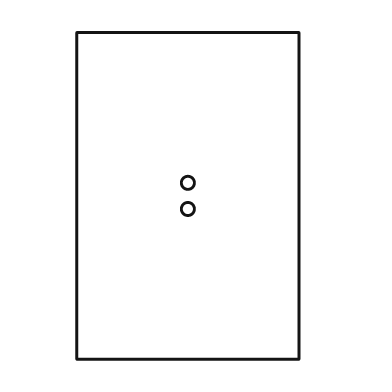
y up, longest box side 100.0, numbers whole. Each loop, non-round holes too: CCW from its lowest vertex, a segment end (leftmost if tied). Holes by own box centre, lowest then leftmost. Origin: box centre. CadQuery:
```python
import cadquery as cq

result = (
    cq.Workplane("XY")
    .moveTo(-34.0, -50.0)
    .lineTo(34.0, -50.0)
    .lineTo(34.0, 50.0)
    .lineTo(-34.0, 50.0)
    .close()
    .moveTo(0.0, -4.0)
    .circle(2.0)
    .moveTo(0.0, 4.0)
    .circle(2.0)
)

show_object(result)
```